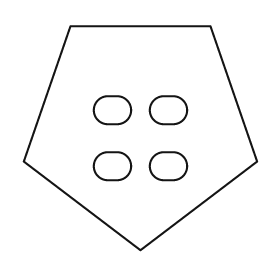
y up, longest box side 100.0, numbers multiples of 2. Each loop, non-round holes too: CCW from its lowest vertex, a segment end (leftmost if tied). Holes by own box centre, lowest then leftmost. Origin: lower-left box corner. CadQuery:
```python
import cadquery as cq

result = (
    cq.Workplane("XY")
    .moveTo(50.0, 0.0)
    .lineTo(100.0, 38.0)
    .lineTo(80.0, 96.0)
    .lineTo(20.0, 96.0)
    .lineTo(0.0, 38.0)
    .close()
    .moveTo(36.0, 30.0)
    .lineTo(40.0, 30.0)
    .threePointArc((46.0, 36.0), (40.0, 42.0))
    .lineTo(36.0, 42.0)
    .threePointArc((30.0, 36.0), (36.0, 30.0))
    .close()
    .moveTo(60.0, 30.0)
    .lineTo(64.0, 30.0)
    .threePointArc((70.0, 36.0), (64.0, 42.0))
    .lineTo(60.0, 42.0)
    .threePointArc((54.0, 36.0), (60.0, 30.0))
    .close()
    .moveTo(36.0, 54.0)
    .lineTo(40.0, 54.0)
    .threePointArc((46.0, 60.0), (40.0, 66.0))
    .lineTo(36.0, 66.0)
    .threePointArc((30.0, 60.0), (36.0, 54.0))
    .close()
    .moveTo(60.0, 54.0)
    .lineTo(64.0, 54.0)
    .threePointArc((70.0, 60.0), (64.0, 66.0))
    .lineTo(60.0, 66.0)
    .threePointArc((54.0, 60.0), (60.0, 54.0))
    .close()
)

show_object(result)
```